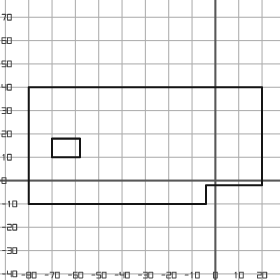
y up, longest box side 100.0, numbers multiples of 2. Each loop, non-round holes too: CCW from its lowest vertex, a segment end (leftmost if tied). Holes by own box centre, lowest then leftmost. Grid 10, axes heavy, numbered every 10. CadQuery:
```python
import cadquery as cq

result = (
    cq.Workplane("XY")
    .moveTo(-80.0, -10.0)
    .lineTo(-4.0, -10.0)
    .lineTo(-4.0, -2.0)
    .lineTo(20.0, -2.0)
    .lineTo(20.0, 40.0)
    .lineTo(-80.0, 40.0)
    .close()
    .moveTo(-70.0, 10.0)
    .lineTo(-58.0, 10.0)
    .lineTo(-58.0, 18.0)
    .lineTo(-70.0, 18.0)
    .close()
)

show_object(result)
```